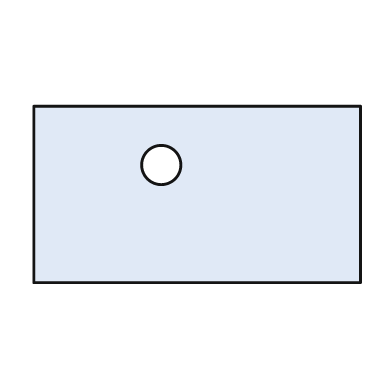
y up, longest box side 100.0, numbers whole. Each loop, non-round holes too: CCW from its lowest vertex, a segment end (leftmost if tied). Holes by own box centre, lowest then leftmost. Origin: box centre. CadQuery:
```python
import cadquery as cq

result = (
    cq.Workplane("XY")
    .moveTo(-50.0, -27.0)
    .lineTo(50.0, -27.0)
    .lineTo(50.0, 27.0)
    .lineTo(-50.0, 27.0)
    .close()
    .moveTo(-11.0, 9.0)
    .circle(6.0)
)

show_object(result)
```